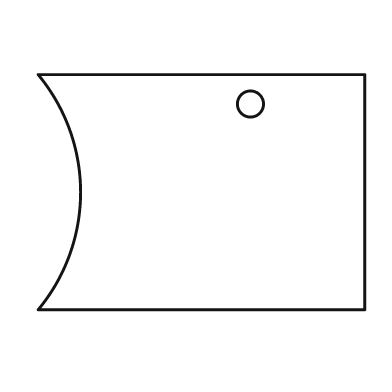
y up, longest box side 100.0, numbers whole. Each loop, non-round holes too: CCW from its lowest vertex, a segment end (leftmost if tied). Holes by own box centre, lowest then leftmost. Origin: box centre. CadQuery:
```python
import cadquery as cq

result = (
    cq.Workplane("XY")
    .moveTo(-50.0, -36.0)
    .lineTo(50.0, -36.0)
    .lineTo(50.0, 36.0)
    .lineTo(-50.0, 36.0)
    .threePointArc((-37.0, 0.0), (-50.0, -36.0))
    .close()
    .moveTo(15.0, 27.0)
    .circle(4.0)
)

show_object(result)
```